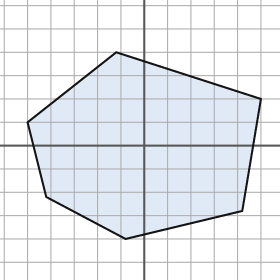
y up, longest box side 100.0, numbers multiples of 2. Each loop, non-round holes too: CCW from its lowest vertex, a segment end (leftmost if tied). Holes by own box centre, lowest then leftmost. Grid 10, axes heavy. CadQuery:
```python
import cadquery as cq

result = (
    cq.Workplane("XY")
    .moveTo(-8.0, -40.0)
    .lineTo(42.0, -28.0)
    .lineTo(50.0, 20.0)
    .lineTo(-12.0, 40.0)
    .lineTo(-50.0, 10.0)
    .lineTo(-42.0, -22.0)
    .close()
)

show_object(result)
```